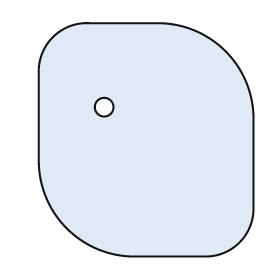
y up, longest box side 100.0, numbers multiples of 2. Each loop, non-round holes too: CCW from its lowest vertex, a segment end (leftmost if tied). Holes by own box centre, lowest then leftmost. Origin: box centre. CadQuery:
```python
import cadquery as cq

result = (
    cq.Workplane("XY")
    .moveTo(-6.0, -50.0)
    .lineTo(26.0, -50.0)
    .threePointArc((40.0, -44.0), (46.0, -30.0))
    .lineTo(46.0, 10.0)
    .threePointArc((34.0, 38.0), (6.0, 50.0))
    .lineTo(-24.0, 50.0)
    .threePointArc((-40.0, 44.0), (-46.0, 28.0))
    .lineTo(-46.0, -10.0)
    .threePointArc((-34.0, -38.0), (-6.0, -50.0))
    .close()
    .moveTo(-18.0, 14.0)
    .circle(4.0)
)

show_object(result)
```